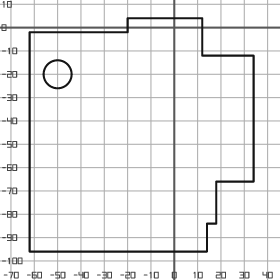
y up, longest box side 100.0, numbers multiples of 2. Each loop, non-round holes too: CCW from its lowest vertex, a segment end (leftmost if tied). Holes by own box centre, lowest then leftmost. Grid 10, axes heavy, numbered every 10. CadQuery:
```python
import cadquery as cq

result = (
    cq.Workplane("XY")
    .moveTo(-62.0, -96.0)
    .lineTo(14.0, -96.0)
    .lineTo(14.0, -84.0)
    .lineTo(18.0, -84.0)
    .lineTo(18.0, -66.0)
    .lineTo(34.0, -66.0)
    .lineTo(34.0, -12.0)
    .lineTo(12.0, -12.0)
    .lineTo(12.0, 4.0)
    .lineTo(-20.0, 4.0)
    .lineTo(-20.0, -2.0)
    .lineTo(-62.0, -2.0)
    .close()
    .moveTo(-50.0, -20.0)
    .circle(6.0)
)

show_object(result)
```